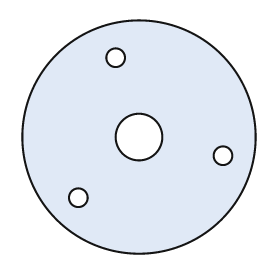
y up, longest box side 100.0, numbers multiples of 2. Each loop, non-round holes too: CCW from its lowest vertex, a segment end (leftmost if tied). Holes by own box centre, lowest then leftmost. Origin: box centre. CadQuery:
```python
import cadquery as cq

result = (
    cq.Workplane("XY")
    .moveTo(0.0, 0.0)
    .circle(50.0)
    .moveTo(-26.0, -26.0)
    .circle(4.0)
    .moveTo(36.0, -8.0)
    .circle(4.0)
    .moveTo(0.0, 0.0)
    .circle(10.0)
    .moveTo(-10.0, 34.0)
    .circle(4.0)
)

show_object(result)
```